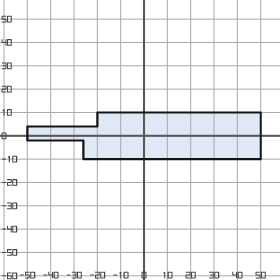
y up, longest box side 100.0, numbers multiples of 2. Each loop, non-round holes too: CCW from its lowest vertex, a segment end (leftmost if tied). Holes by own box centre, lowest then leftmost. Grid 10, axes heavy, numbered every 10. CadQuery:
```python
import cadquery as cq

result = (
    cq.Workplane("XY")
    .moveTo(-26.0, -10.0)
    .lineTo(50.0, -10.0)
    .lineTo(50.0, 10.0)
    .lineTo(-20.0, 10.0)
    .lineTo(-20.0, 4.0)
    .lineTo(-50.0, 4.0)
    .lineTo(-50.0, -2.0)
    .lineTo(-26.0, -2.0)
    .close()
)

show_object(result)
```